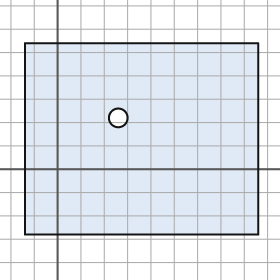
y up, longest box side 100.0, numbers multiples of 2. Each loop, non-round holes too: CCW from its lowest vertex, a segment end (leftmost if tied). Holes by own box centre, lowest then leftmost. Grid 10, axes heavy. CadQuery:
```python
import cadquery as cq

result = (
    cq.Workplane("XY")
    .moveTo(-14.0, -28.0)
    .lineTo(86.0, -28.0)
    .lineTo(86.0, 54.0)
    .lineTo(-14.0, 54.0)
    .close()
    .moveTo(26.0, 22.0)
    .circle(4.0)
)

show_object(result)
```